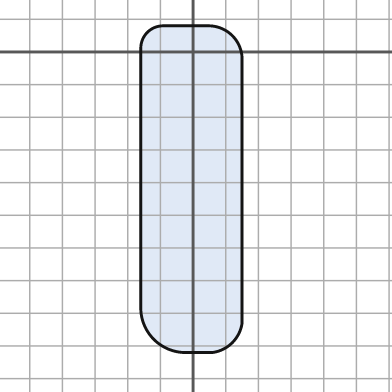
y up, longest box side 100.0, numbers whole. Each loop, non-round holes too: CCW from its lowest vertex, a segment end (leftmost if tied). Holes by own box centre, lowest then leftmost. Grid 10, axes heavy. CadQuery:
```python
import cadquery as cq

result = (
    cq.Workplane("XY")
    .moveTo(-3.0, -92.0)
    .lineTo(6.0, -92.0)
    .threePointArc((12.0, -89.0), (15.0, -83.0))
    .lineTo(15.0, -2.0)
    .threePointArc((12.0, 5.0), (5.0, 8.0))
    .lineTo(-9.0, 8.0)
    .threePointArc((-14.0, 6.0), (-16.0, 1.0))
    .lineTo(-16.0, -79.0)
    .threePointArc((-12.0, -88.0), (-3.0, -92.0))
    .close()
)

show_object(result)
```